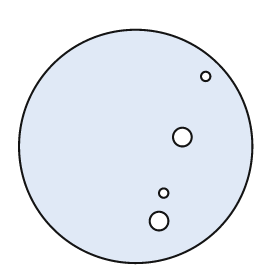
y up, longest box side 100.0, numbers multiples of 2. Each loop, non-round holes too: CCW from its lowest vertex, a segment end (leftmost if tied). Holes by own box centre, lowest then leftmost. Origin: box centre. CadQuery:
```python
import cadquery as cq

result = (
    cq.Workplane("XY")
    .moveTo(0.0, 0.0)
    .circle(50.0)
    .moveTo(10.0, -32.0)
    .circle(4.0)
    .moveTo(12.0, -20.0)
    .circle(2.0)
    .moveTo(20.0, 4.0)
    .circle(4.0)
    .moveTo(30.0, 30.0)
    .circle(2.0)
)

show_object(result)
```